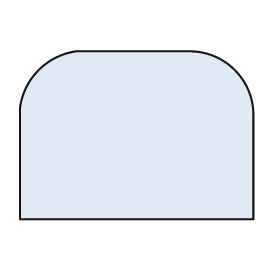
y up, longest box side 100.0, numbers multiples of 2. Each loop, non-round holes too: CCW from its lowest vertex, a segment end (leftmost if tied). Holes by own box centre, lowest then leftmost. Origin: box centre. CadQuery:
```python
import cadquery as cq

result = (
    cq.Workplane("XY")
    .moveTo(-50.0, -36.0)
    .lineTo(50.0, -36.0)
    .lineTo(50.0, 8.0)
    .threePointArc((42.0, 28.0), (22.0, 36.0))
    .lineTo(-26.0, 36.0)
    .threePointArc((-42.0, 28.0), (-50.0, 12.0))
    .close()
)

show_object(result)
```